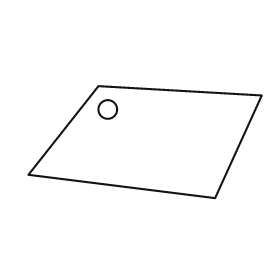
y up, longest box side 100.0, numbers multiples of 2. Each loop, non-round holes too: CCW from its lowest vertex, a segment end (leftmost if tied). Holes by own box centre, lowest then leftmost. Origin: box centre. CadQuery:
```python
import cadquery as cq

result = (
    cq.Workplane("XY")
    .moveTo(30.0, -24.0)
    .lineTo(50.0, 20.0)
    .lineTo(-20.0, 24.0)
    .lineTo(-50.0, -14.0)
    .close()
    .moveTo(-16.0, 14.0)
    .circle(4.0)
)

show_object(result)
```